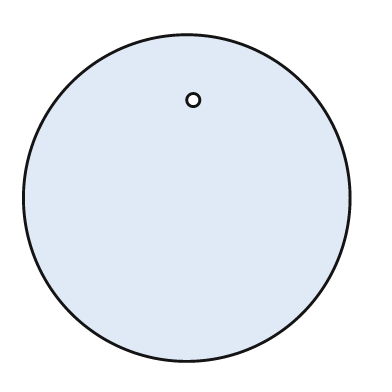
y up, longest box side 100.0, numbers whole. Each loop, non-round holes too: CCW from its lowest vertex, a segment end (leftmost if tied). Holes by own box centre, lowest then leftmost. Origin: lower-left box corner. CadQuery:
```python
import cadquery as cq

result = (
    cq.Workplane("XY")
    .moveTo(50.0, 50.0)
    .circle(50.0)
    .moveTo(52.0, 80.0)
    .circle(2.0)
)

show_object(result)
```